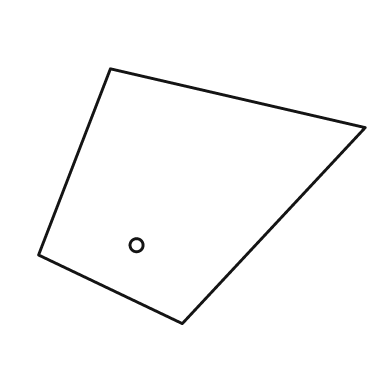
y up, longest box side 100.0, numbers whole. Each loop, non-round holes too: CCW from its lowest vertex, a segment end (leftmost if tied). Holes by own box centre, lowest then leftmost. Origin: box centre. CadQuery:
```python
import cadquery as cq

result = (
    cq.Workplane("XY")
    .moveTo(-6.0, -39.0)
    .lineTo(50.0, 21.0)
    .lineTo(-28.0, 39.0)
    .lineTo(-50.0, -18.0)
    .close()
    .moveTo(-20.0, -15.0)
    .circle(2.0)
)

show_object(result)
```